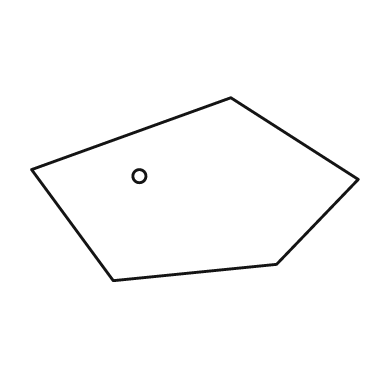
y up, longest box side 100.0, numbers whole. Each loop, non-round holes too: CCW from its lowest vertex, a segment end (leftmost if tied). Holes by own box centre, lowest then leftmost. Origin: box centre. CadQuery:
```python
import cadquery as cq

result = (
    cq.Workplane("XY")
    .moveTo(-25.0, -28.0)
    .lineTo(25.0, -23.0)
    .lineTo(50.0, 3.0)
    .lineTo(11.0, 28.0)
    .lineTo(-50.0, 6.0)
    .close()
    .moveTo(-17.0, 4.0)
    .circle(2.0)
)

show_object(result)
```